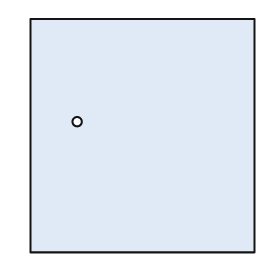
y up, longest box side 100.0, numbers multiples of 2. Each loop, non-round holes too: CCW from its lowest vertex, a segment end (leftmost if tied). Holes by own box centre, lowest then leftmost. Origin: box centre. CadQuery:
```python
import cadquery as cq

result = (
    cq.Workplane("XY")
    .moveTo(-48.0, -50.0)
    .lineTo(48.0, -50.0)
    .lineTo(48.0, 50.0)
    .lineTo(-48.0, 50.0)
    .close()
    .moveTo(-28.0, 6.0)
    .circle(2.0)
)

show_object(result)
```